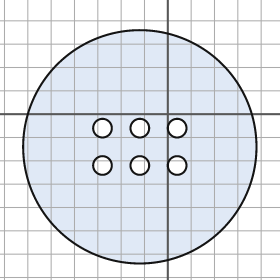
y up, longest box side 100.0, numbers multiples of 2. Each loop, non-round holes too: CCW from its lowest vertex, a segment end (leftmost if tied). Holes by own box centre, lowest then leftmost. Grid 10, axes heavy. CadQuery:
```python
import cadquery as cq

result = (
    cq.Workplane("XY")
    .moveTo(-12.0, -14.0)
    .circle(50.0)
    .moveTo(-28.0, -22.0)
    .circle(4.0)
    .moveTo(-12.0, -22.0)
    .circle(4.0)
    .moveTo(4.0, -22.0)
    .circle(4.0)
    .moveTo(-28.0, -6.0)
    .circle(4.0)
    .moveTo(-12.0, -6.0)
    .circle(4.0)
    .moveTo(4.0, -6.0)
    .circle(4.0)
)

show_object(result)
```